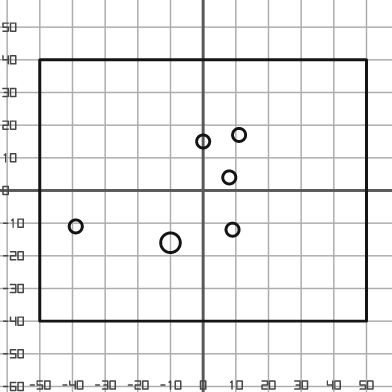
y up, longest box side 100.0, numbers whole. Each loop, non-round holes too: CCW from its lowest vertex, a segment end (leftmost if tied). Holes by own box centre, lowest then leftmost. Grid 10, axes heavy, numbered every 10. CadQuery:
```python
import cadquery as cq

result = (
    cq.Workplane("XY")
    .moveTo(-50.0, -40.0)
    .lineTo(50.0, -40.0)
    .lineTo(50.0, 40.0)
    .lineTo(-50.0, 40.0)
    .close()
    .moveTo(-10.0, -16.0)
    .circle(3.0)
    .moveTo(9.0, -12.0)
    .circle(2.0)
    .moveTo(-39.0, -11.0)
    .circle(2.0)
    .moveTo(8.0, 4.0)
    .circle(2.0)
    .moveTo(0.0, 15.0)
    .circle(2.0)
    .moveTo(11.0, 17.0)
    .circle(2.0)
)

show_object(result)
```